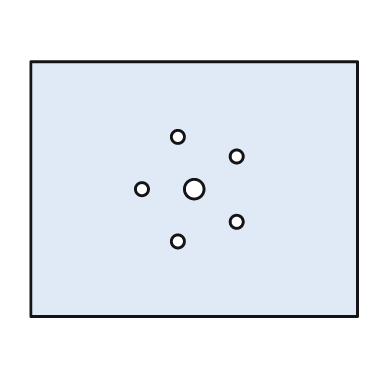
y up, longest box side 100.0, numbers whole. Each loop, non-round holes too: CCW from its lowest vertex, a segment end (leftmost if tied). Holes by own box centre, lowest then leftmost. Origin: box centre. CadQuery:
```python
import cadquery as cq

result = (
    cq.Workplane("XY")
    .moveTo(-50.0, -39.0)
    .lineTo(50.0, -39.0)
    .lineTo(50.0, 39.0)
    .lineTo(-50.0, 39.0)
    .close()
    .moveTo(-5.0, -16.0)
    .circle(2.0)
    .moveTo(13.0, -10.0)
    .circle(2.0)
    .moveTo(-16.0, 0.0)
    .circle(2.0)
    .moveTo(0.0, 0.0)
    .circle(3.0)
    .moveTo(13.0, 10.0)
    .circle(2.0)
    .moveTo(-5.0, 16.0)
    .circle(2.0)
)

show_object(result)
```